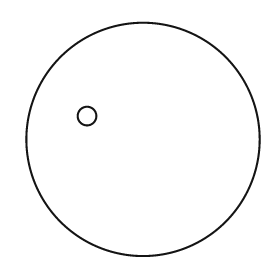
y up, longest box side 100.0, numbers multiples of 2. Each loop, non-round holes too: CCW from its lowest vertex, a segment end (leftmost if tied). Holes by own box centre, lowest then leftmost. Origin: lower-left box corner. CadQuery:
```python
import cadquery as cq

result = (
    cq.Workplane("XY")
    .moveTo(50.0, 50.0)
    .circle(50.0)
    .moveTo(26.0, 60.0)
    .circle(4.0)
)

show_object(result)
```